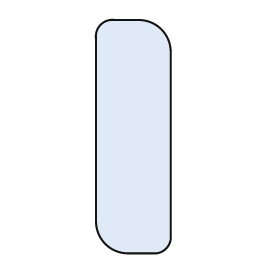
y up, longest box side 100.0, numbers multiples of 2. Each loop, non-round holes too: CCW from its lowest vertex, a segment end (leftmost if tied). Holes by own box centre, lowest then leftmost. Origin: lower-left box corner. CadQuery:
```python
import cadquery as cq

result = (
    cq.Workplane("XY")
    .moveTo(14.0, 0.0)
    .lineTo(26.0, 0.0)
    .threePointArc((30.0, 2.0), (32.0, 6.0))
    .lineTo(32.0, 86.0)
    .threePointArc((28.0, 96.0), (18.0, 100.0))
    .lineTo(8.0, 100.0)
    .threePointArc((2.0, 98.0), (0.0, 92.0))
    .lineTo(0.0, 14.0)
    .threePointArc((4.0, 4.0), (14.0, 0.0))
    .close()
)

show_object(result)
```